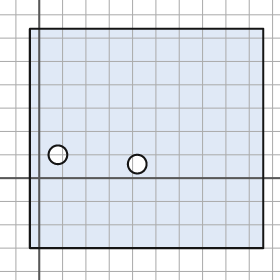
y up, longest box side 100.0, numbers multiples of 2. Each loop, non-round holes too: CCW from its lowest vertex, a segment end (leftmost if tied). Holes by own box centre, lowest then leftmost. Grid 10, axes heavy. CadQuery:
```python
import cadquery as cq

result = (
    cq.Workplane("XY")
    .moveTo(-4.0, -30.0)
    .lineTo(96.0, -30.0)
    .lineTo(96.0, 64.0)
    .lineTo(-4.0, 64.0)
    .close()
    .moveTo(42.0, 6.0)
    .circle(4.0)
    .moveTo(8.0, 10.0)
    .circle(4.0)
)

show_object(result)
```